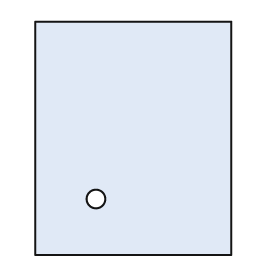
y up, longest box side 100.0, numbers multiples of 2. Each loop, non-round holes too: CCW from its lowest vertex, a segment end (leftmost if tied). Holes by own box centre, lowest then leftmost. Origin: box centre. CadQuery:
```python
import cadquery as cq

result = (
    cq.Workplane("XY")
    .moveTo(-42.0, -50.0)
    .lineTo(42.0, -50.0)
    .lineTo(42.0, 50.0)
    .lineTo(-42.0, 50.0)
    .close()
    .moveTo(-16.0, -26.0)
    .circle(4.0)
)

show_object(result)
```